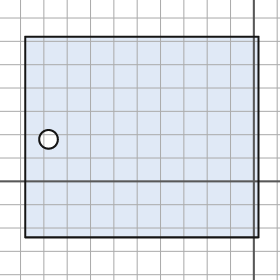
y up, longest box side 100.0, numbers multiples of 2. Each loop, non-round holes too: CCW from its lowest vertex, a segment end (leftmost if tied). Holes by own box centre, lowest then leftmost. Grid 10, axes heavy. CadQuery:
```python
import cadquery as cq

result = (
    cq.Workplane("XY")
    .moveTo(-98.0, -24.0)
    .lineTo(2.0, -24.0)
    .lineTo(2.0, 62.0)
    .lineTo(-98.0, 62.0)
    .close()
    .moveTo(-88.0, 18.0)
    .circle(4.0)
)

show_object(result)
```